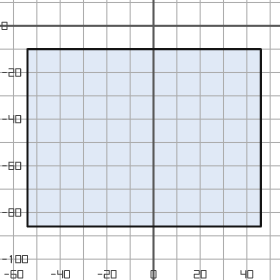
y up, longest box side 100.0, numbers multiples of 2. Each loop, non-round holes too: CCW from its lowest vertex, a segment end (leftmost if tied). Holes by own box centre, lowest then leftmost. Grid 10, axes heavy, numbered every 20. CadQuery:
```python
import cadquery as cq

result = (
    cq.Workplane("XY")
    .moveTo(-54.0, -86.0)
    .lineTo(46.0, -86.0)
    .lineTo(46.0, -10.0)
    .lineTo(-54.0, -10.0)
    .close()
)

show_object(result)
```